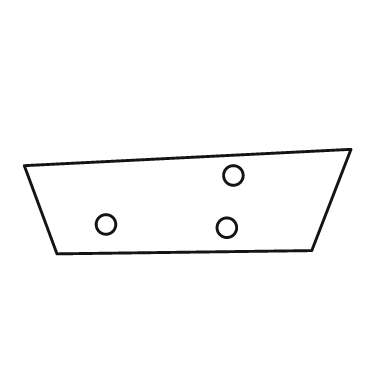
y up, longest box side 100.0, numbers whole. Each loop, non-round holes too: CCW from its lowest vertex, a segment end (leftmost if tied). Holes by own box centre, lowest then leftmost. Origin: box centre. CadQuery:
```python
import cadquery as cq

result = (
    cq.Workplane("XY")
    .moveTo(-40.0, -16.0)
    .lineTo(38.0, -15.0)
    .lineTo(50.0, 16.0)
    .lineTo(-50.0, 11.0)
    .close()
    .moveTo(12.0, -8.0)
    .circle(3.0)
    .moveTo(-25.0, -7.0)
    .circle(3.0)
    .moveTo(14.0, 8.0)
    .circle(3.0)
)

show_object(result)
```